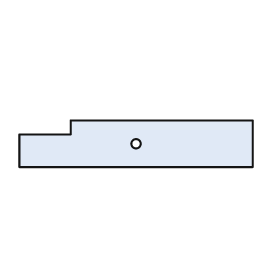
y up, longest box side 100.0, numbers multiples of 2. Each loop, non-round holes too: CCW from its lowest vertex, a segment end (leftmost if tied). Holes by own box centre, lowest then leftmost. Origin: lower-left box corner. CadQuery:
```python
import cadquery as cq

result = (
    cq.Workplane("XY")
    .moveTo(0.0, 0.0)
    .lineTo(100.0, 0.0)
    .lineTo(100.0, 20.0)
    .lineTo(22.0, 20.0)
    .lineTo(22.0, 14.0)
    .lineTo(0.0, 14.0)
    .close()
    .moveTo(50.0, 10.0)
    .circle(2.0)
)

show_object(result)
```